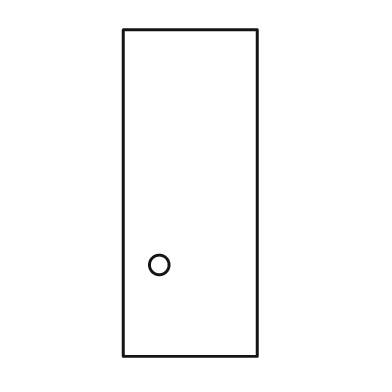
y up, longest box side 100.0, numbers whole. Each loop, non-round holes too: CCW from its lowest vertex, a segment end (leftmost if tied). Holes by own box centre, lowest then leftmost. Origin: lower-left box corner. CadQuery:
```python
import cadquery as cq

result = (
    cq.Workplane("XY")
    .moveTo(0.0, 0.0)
    .lineTo(41.0, 0.0)
    .lineTo(41.0, 100.0)
    .lineTo(0.0, 100.0)
    .close()
    .moveTo(11.0, 28.0)
    .circle(3.0)
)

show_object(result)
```